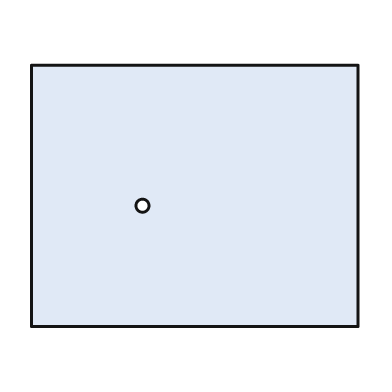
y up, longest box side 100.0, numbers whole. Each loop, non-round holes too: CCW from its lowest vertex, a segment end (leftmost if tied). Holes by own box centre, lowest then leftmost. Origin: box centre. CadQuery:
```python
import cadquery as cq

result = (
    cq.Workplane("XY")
    .moveTo(-50.0, -40.0)
    .lineTo(50.0, -40.0)
    .lineTo(50.0, 40.0)
    .lineTo(-50.0, 40.0)
    .close()
    .moveTo(-16.0, -3.0)
    .circle(2.0)
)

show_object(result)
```